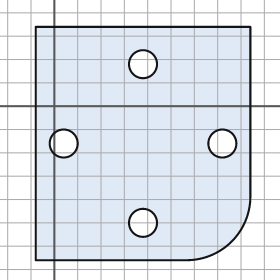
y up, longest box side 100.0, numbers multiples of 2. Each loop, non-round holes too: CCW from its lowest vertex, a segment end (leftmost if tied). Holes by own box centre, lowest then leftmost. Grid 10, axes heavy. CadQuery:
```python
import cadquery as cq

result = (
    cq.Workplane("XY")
    .moveTo(-8.0, -66.0)
    .lineTo(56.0, -66.0)
    .threePointArc((76.0, -58.0), (84.0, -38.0))
    .lineTo(84.0, 34.0)
    .lineTo(-8.0, 34.0)
    .close()
    .moveTo(38.0, -50.0)
    .circle(6.0)
    .moveTo(4.0, -16.0)
    .circle(6.0)
    .moveTo(72.0, -16.0)
    .circle(6.0)
    .moveTo(38.0, 18.0)
    .circle(6.0)
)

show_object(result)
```